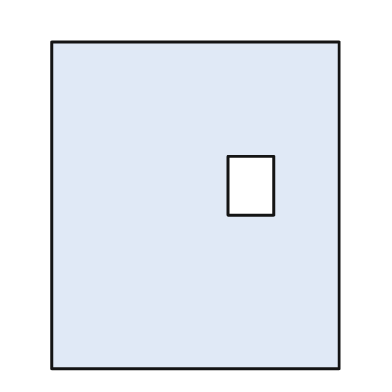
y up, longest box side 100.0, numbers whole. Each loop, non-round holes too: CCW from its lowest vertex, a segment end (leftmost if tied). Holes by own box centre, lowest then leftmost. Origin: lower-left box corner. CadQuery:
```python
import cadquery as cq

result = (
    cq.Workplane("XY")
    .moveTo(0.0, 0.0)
    .lineTo(88.0, 0.0)
    .lineTo(88.0, 100.0)
    .lineTo(0.0, 100.0)
    .close()
    .moveTo(54.0, 47.0)
    .lineTo(68.0, 47.0)
    .lineTo(68.0, 65.0)
    .lineTo(54.0, 65.0)
    .close()
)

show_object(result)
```